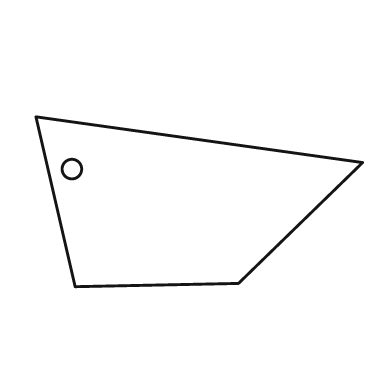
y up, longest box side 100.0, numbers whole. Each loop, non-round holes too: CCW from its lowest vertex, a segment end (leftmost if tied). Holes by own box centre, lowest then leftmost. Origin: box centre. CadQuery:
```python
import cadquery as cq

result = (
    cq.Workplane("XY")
    .moveTo(-38.0, -26.0)
    .lineTo(12.0, -25.0)
    .lineTo(50.0, 12.0)
    .lineTo(-50.0, 26.0)
    .close()
    .moveTo(-39.0, 10.0)
    .circle(3.0)
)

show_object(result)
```